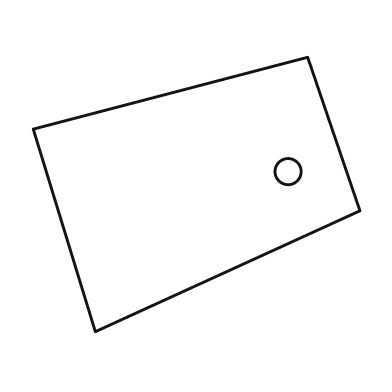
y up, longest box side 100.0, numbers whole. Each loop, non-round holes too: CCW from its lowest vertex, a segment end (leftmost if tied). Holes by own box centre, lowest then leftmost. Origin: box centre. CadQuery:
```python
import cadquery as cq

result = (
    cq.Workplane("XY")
    .moveTo(-31.0, -42.0)
    .lineTo(50.0, -5.0)
    .lineTo(34.0, 42.0)
    .lineTo(-50.0, 20.0)
    .close()
    .moveTo(28.0, 7.0)
    .circle(4.0)
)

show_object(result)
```